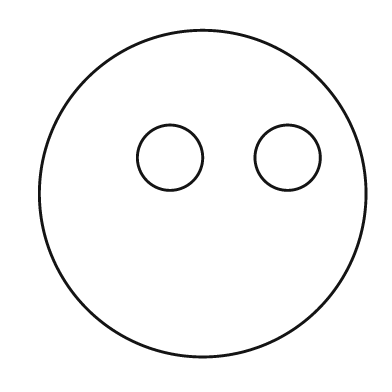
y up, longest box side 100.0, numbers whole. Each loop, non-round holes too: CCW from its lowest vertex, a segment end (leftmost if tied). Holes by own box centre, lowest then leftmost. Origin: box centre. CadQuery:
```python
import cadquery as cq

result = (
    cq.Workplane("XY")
    .moveTo(0.0, 0.0)
    .circle(50.0)
    .moveTo(-10.0, 11.0)
    .circle(10.0)
    .moveTo(26.0, 11.0)
    .circle(10.0)
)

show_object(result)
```